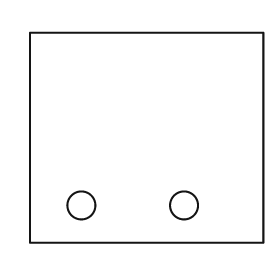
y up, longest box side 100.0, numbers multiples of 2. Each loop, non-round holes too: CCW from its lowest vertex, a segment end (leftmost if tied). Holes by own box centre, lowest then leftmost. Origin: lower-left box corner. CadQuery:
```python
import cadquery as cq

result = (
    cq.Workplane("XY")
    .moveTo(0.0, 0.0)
    .lineTo(100.0, 0.0)
    .lineTo(100.0, 90.0)
    .lineTo(0.0, 90.0)
    .close()
    .moveTo(22.0, 16.0)
    .circle(6.0)
    .moveTo(66.0, 16.0)
    .circle(6.0)
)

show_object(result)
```